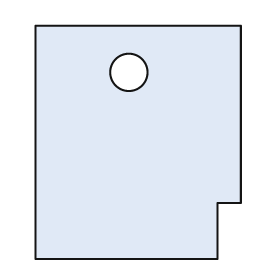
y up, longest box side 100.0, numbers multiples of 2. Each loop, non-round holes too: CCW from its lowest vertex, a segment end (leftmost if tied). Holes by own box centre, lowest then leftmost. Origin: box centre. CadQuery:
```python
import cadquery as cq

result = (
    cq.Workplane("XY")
    .moveTo(-44.0, -50.0)
    .lineTo(34.0, -50.0)
    .lineTo(34.0, -26.0)
    .lineTo(44.0, -26.0)
    .lineTo(44.0, 50.0)
    .lineTo(-44.0, 50.0)
    .close()
    .moveTo(-4.0, 30.0)
    .circle(8.0)
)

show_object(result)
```